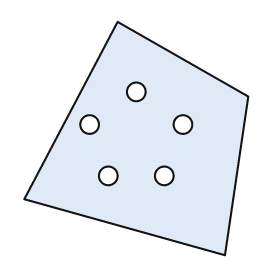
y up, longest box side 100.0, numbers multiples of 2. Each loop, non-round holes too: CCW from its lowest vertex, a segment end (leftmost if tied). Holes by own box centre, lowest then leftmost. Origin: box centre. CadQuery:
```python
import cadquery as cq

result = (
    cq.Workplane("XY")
    .moveTo(38.0, -50.0)
    .lineTo(48.0, 18.0)
    .lineTo(-8.0, 50.0)
    .lineTo(-48.0, -26.0)
    .close()
    .moveTo(-12.0, -16.0)
    .circle(4.0)
    .moveTo(12.0, -16.0)
    .circle(4.0)
    .moveTo(-20.0, 6.0)
    .circle(4.0)
    .moveTo(20.0, 6.0)
    .circle(4.0)
    .moveTo(0.0, 20.0)
    .circle(4.0)
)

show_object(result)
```